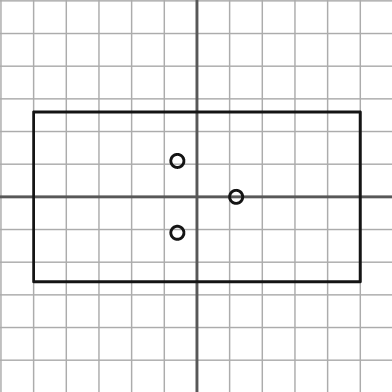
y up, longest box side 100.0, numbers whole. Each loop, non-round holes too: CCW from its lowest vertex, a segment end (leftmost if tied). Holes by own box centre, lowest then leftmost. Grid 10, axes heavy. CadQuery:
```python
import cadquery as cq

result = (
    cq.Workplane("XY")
    .moveTo(-50.0, -26.0)
    .lineTo(50.0, -26.0)
    .lineTo(50.0, 26.0)
    .lineTo(-50.0, 26.0)
    .close()
    .moveTo(-6.0, -11.0)
    .circle(2.0)
    .moveTo(12.0, 0.0)
    .circle(2.0)
    .moveTo(-6.0, 11.0)
    .circle(2.0)
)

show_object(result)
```